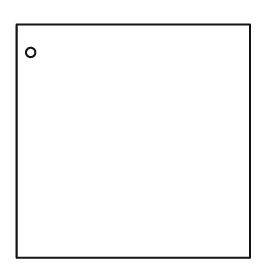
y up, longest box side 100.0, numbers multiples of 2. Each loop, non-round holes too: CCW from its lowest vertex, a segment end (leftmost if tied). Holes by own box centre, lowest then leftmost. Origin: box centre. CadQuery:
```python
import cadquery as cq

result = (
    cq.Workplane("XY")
    .moveTo(-50.0, -50.0)
    .lineTo(50.0, -50.0)
    .lineTo(50.0, 50.0)
    .lineTo(-50.0, 50.0)
    .close()
    .moveTo(-44.0, 38.0)
    .circle(2.0)
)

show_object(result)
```